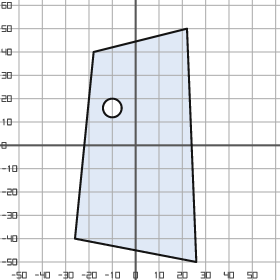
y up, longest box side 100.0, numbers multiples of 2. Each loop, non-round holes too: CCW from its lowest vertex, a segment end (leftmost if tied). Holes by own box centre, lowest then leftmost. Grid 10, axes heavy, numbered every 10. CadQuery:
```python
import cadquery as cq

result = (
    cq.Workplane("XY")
    .moveTo(26.0, -50.0)
    .lineTo(22.0, 50.0)
    .lineTo(-18.0, 40.0)
    .lineTo(-26.0, -40.0)
    .close()
    .moveTo(-10.0, 16.0)
    .circle(4.0)
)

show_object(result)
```